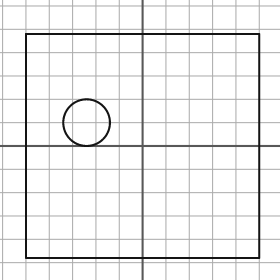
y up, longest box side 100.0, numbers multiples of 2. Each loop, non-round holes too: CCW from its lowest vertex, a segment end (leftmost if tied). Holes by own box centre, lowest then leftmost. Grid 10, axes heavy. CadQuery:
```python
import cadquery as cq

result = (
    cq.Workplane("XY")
    .moveTo(-50.0, -48.0)
    .lineTo(50.0, -48.0)
    .lineTo(50.0, 48.0)
    .lineTo(-50.0, 48.0)
    .close()
    .moveTo(-24.0, 10.0)
    .circle(10.0)
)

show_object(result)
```